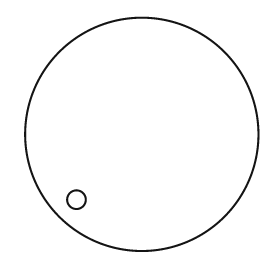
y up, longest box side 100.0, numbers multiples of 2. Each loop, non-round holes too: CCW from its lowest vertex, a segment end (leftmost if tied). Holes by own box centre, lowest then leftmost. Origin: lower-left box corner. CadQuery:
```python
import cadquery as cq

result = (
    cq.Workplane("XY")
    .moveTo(50.0, 50.0)
    .circle(50.0)
    .moveTo(22.0, 22.0)
    .circle(4.0)
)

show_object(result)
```